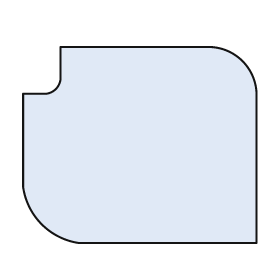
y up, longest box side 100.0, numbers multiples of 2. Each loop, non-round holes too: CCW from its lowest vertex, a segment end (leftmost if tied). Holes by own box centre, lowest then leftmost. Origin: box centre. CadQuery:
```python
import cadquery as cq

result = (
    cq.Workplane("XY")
    .moveTo(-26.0, -42.0)
    .lineTo(50.0, -42.0)
    .lineTo(50.0, 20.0)
    .threePointArc((44.0, 36.0), (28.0, 42.0))
    .lineTo(-34.0, 42.0)
    .lineTo(-34.0, 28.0)
    .threePointArc((-36.0, 24.0), (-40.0, 22.0))
    .lineTo(-50.0, 22.0)
    .lineTo(-50.0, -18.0)
    .threePointArc((-42.0, -34.0), (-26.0, -42.0))
    .close()
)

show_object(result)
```